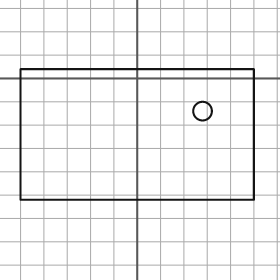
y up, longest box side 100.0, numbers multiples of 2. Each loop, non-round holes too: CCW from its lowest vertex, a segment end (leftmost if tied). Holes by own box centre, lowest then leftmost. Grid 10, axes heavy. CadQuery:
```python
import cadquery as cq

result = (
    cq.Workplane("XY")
    .moveTo(-50.0, -52.0)
    .lineTo(50.0, -52.0)
    .lineTo(50.0, 4.0)
    .lineTo(-50.0, 4.0)
    .close()
    .moveTo(28.0, -14.0)
    .circle(4.0)
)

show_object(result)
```